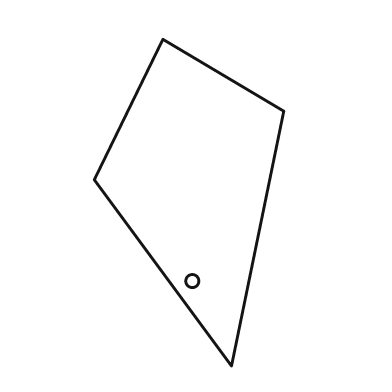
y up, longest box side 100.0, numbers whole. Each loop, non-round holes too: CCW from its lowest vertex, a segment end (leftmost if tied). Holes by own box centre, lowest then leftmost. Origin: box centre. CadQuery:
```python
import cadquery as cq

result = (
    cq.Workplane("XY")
    .moveTo(13.0, -50.0)
    .lineTo(29.0, 28.0)
    .lineTo(-8.0, 50.0)
    .lineTo(-29.0, 7.0)
    .close()
    .moveTo(1.0, -24.0)
    .circle(2.0)
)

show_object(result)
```